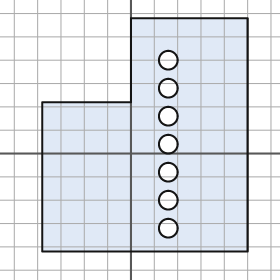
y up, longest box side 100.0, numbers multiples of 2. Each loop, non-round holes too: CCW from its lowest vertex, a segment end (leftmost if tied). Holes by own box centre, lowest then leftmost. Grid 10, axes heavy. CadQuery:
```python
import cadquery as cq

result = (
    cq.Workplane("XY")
    .moveTo(-38.0, -42.0)
    .lineTo(50.0, -42.0)
    .lineTo(50.0, 58.0)
    .lineTo(0.0, 58.0)
    .lineTo(0.0, 22.0)
    .lineTo(-38.0, 22.0)
    .close()
    .moveTo(16.0, -32.0)
    .circle(4.0)
    .moveTo(16.0, -20.0)
    .circle(4.0)
    .moveTo(16.0, -8.0)
    .circle(4.0)
    .moveTo(16.0, 4.0)
    .circle(4.0)
    .moveTo(16.0, 16.0)
    .circle(4.0)
    .moveTo(16.0, 28.0)
    .circle(4.0)
    .moveTo(16.0, 40.0)
    .circle(4.0)
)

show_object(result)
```